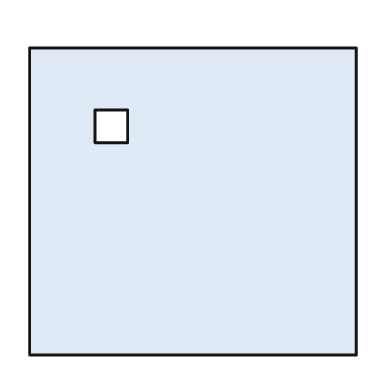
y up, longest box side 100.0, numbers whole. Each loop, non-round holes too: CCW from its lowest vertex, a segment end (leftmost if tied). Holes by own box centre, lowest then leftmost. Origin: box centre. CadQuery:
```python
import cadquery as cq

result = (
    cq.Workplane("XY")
    .moveTo(-50.0, -47.0)
    .lineTo(50.0, -47.0)
    .lineTo(50.0, 47.0)
    .lineTo(-50.0, 47.0)
    .close()
    .moveTo(-30.0, 18.0)
    .lineTo(-20.0, 18.0)
    .lineTo(-20.0, 28.0)
    .lineTo(-30.0, 28.0)
    .close()
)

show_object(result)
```